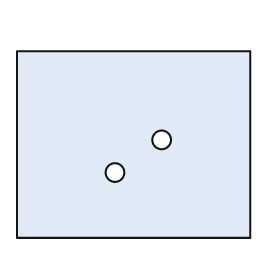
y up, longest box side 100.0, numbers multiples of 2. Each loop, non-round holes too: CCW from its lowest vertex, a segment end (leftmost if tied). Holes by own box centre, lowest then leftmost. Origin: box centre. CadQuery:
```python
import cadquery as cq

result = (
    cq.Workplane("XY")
    .moveTo(-50.0, -40.0)
    .lineTo(50.0, -40.0)
    .lineTo(50.0, 40.0)
    .lineTo(-50.0, 40.0)
    .close()
    .moveTo(-8.0, -12.0)
    .circle(4.0)
    .moveTo(12.0, 2.0)
    .circle(4.0)
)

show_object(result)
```